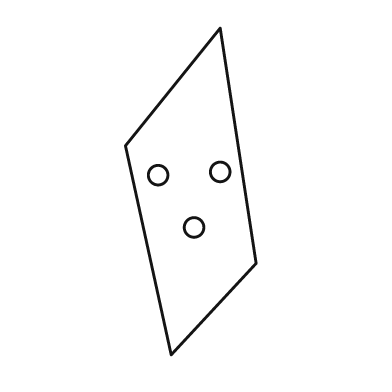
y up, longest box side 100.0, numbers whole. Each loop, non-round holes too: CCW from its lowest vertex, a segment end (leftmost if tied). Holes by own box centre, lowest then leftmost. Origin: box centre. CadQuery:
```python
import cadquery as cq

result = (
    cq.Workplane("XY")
    .moveTo(-6.0, -50.0)
    .lineTo(20.0, -22.0)
    .lineTo(9.0, 50.0)
    .lineTo(-20.0, 14.0)
    .close()
    .moveTo(1.0, -11.0)
    .circle(3.0)
    .moveTo(-10.0, 5.0)
    .circle(3.0)
    .moveTo(9.0, 6.0)
    .circle(3.0)
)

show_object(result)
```